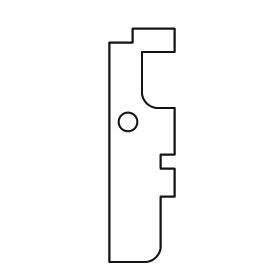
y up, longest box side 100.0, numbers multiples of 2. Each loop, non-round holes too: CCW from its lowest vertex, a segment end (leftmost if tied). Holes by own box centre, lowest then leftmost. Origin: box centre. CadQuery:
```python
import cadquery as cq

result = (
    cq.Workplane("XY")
    .moveTo(-14.0, -50.0)
    .lineTo(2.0, -50.0)
    .threePointArc((6.0, -48.0), (8.0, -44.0))
    .lineTo(8.0, -22.0)
    .lineTo(14.0, -22.0)
    .lineTo(14.0, -10.0)
    .lineTo(8.0, -10.0)
    .lineTo(8.0, -4.0)
    .lineTo(14.0, -4.0)
    .lineTo(14.0, 16.0)
    .lineTo(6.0, 16.0)
    .threePointArc((2.0, 18.0), (0.0, 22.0))
    .lineTo(0.0, 40.0)
    .lineTo(14.0, 40.0)
    .lineTo(14.0, 50.0)
    .lineTo(-4.0, 50.0)
    .lineTo(-4.0, 44.0)
    .lineTo(-14.0, 44.0)
    .close()
    .moveTo(-6.0, 10.0)
    .circle(4.0)
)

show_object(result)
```